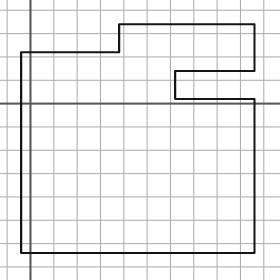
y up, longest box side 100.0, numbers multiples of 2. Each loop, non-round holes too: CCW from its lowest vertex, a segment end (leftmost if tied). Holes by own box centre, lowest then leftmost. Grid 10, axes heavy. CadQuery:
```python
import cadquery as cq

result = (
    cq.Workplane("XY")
    .moveTo(-4.0, -64.0)
    .lineTo(96.0, -64.0)
    .lineTo(96.0, 2.0)
    .lineTo(62.0, 2.0)
    .lineTo(62.0, 14.0)
    .lineTo(96.0, 14.0)
    .lineTo(96.0, 34.0)
    .lineTo(38.0, 34.0)
    .lineTo(38.0, 22.0)
    .lineTo(-4.0, 22.0)
    .close()
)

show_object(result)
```